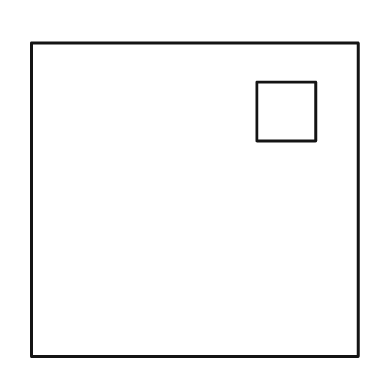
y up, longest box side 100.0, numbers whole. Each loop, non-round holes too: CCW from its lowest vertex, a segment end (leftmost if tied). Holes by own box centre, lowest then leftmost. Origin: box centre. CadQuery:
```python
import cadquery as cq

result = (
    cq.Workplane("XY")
    .moveTo(-50.0, -48.0)
    .lineTo(50.0, -48.0)
    .lineTo(50.0, 48.0)
    .lineTo(-50.0, 48.0)
    .close()
    .moveTo(19.0, 18.0)
    .lineTo(37.0, 18.0)
    .lineTo(37.0, 36.0)
    .lineTo(19.0, 36.0)
    .close()
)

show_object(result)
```